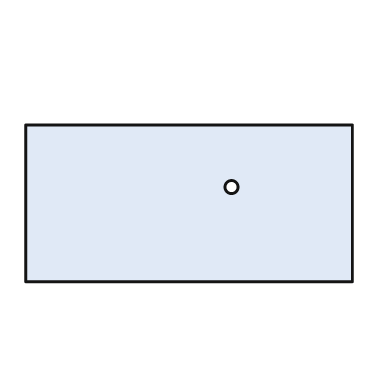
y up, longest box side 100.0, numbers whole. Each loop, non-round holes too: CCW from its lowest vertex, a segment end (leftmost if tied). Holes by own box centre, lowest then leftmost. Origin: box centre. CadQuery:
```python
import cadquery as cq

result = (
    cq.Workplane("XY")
    .moveTo(-50.0, -24.0)
    .lineTo(50.0, -24.0)
    .lineTo(50.0, 24.0)
    .lineTo(-50.0, 24.0)
    .close()
    .moveTo(13.0, 5.0)
    .circle(2.0)
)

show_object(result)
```